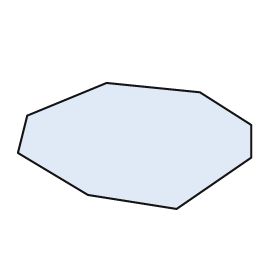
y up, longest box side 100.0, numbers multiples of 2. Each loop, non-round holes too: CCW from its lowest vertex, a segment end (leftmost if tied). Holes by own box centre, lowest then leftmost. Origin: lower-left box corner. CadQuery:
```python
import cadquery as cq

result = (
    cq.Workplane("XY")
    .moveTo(68.0, 0.0)
    .lineTo(100.0, 22.0)
    .lineTo(100.0, 36.0)
    .lineTo(78.0, 50.0)
    .lineTo(38.0, 54.0)
    .lineTo(4.0, 40.0)
    .lineTo(0.0, 24.0)
    .lineTo(30.0, 6.0)
    .close()
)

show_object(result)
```